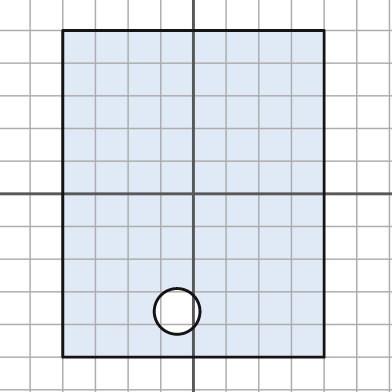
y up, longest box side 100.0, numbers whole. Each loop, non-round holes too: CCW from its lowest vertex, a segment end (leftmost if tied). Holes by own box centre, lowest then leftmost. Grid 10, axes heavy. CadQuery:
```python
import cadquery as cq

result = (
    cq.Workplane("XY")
    .moveTo(-40.0, -50.0)
    .lineTo(40.0, -50.0)
    .lineTo(40.0, 50.0)
    .lineTo(-40.0, 50.0)
    .close()
    .moveTo(-5.0, -36.0)
    .circle(7.0)
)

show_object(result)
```